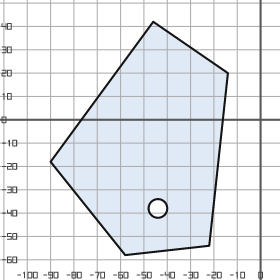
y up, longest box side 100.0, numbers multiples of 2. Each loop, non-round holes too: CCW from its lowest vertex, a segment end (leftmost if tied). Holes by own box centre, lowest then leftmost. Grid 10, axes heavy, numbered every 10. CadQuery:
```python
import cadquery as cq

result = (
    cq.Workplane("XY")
    .moveTo(-58.0, -58.0)
    .lineTo(-22.0, -54.0)
    .lineTo(-14.0, 20.0)
    .lineTo(-46.0, 42.0)
    .lineTo(-90.0, -18.0)
    .close()
    .moveTo(-44.0, -38.0)
    .circle(4.0)
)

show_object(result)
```